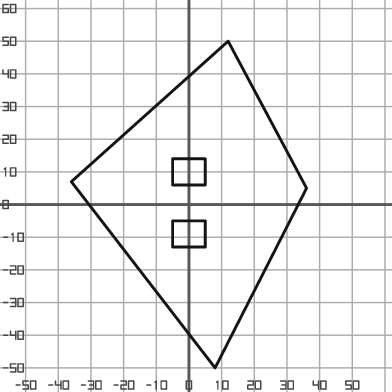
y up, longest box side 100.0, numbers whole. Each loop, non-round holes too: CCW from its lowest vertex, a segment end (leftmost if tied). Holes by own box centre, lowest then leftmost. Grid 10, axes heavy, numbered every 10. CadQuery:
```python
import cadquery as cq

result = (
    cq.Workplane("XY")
    .moveTo(8.0, -50.0)
    .lineTo(36.0, 5.0)
    .lineTo(12.0, 50.0)
    .lineTo(-36.0, 7.0)
    .close()
    .moveTo(-5.0, -13.0)
    .lineTo(5.0, -13.0)
    .lineTo(5.0, -5.0)
    .lineTo(-5.0, -5.0)
    .close()
    .moveTo(-5.0, 6.0)
    .lineTo(5.0, 6.0)
    .lineTo(5.0, 14.0)
    .lineTo(-5.0, 14.0)
    .close()
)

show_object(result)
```